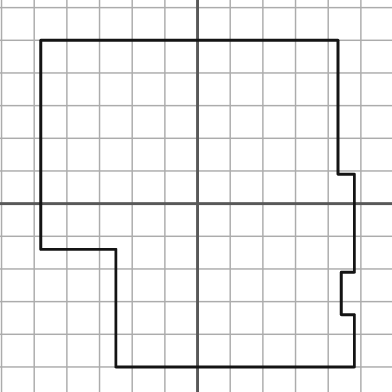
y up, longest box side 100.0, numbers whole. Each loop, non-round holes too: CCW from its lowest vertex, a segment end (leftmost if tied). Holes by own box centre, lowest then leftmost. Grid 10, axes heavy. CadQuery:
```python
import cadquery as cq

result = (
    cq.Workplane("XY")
    .moveTo(-25.0, -50.0)
    .lineTo(48.0, -50.0)
    .lineTo(48.0, -34.0)
    .lineTo(44.0, -34.0)
    .lineTo(44.0, -21.0)
    .lineTo(48.0, -21.0)
    .lineTo(48.0, 9.0)
    .lineTo(43.0, 9.0)
    .lineTo(43.0, 50.0)
    .lineTo(-48.0, 50.0)
    .lineTo(-48.0, -14.0)
    .lineTo(-25.0, -14.0)
    .close()
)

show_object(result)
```